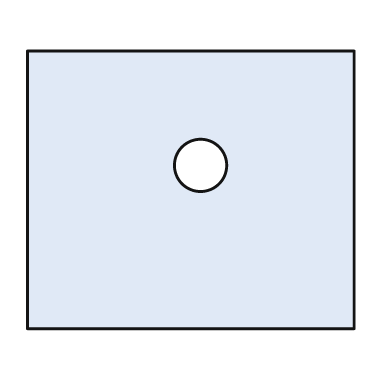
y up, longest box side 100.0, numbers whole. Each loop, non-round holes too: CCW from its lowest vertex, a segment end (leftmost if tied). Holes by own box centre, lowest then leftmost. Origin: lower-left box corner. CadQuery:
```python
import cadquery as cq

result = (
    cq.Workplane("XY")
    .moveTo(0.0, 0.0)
    .lineTo(100.0, 0.0)
    .lineTo(100.0, 85.0)
    .lineTo(0.0, 85.0)
    .close()
    .moveTo(53.0, 50.0)
    .circle(8.0)
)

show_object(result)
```